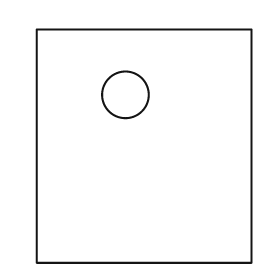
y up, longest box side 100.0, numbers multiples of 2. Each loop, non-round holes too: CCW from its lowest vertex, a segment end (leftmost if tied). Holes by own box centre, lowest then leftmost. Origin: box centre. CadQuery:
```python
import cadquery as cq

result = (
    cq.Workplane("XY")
    .moveTo(-46.0, -50.0)
    .lineTo(46.0, -50.0)
    .lineTo(46.0, 50.0)
    .lineTo(-46.0, 50.0)
    .close()
    .moveTo(-8.0, 22.0)
    .circle(10.0)
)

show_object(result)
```